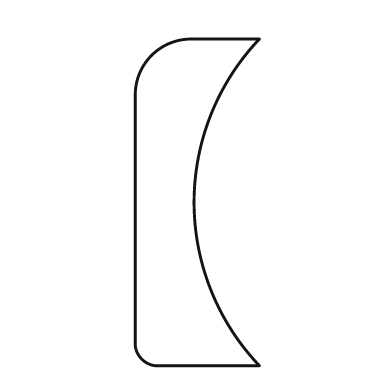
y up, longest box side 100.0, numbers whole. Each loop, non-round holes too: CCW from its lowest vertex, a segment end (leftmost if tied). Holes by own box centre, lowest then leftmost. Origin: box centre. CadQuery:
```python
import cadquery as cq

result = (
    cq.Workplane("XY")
    .moveTo(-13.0, -50.0)
    .lineTo(19.0, -50.0)
    .threePointArc((-1.0, 0.0), (19.0, 50.0))
    .lineTo(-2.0, 50.0)
    .threePointArc((-14.0, 45.0), (-19.0, 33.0))
    .lineTo(-19.0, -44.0)
    .threePointArc((-17.0, -48.0), (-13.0, -50.0))
    .close()
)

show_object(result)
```